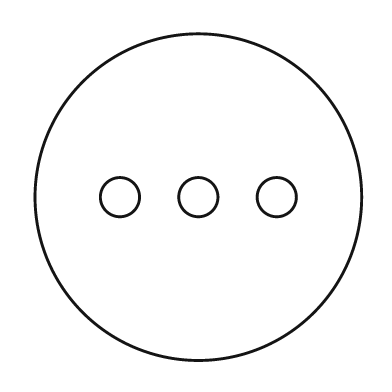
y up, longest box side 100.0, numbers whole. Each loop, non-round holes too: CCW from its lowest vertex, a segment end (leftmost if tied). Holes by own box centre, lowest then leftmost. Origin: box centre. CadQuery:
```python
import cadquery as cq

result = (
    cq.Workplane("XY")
    .moveTo(0.0, 0.0)
    .circle(50.0)
    .moveTo(-24.0, 0.0)
    .circle(6.0)
    .moveTo(0.0, 0.0)
    .circle(6.0)
    .moveTo(24.0, 0.0)
    .circle(6.0)
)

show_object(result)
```